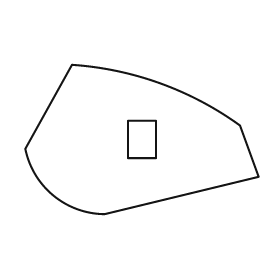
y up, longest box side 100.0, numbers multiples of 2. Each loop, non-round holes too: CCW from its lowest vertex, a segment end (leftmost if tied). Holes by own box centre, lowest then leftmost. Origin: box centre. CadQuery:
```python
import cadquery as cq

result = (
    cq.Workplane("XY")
    .moveTo(-16.0, -32.0)
    .lineTo(50.0, -16.0)
    .lineTo(42.0, 6.0)
    .threePointArc((8.0, 24.0), (-30.0, 32.0))
    .lineTo(-50.0, -4.0)
    .threePointArc((-38.0, -24.0), (-16.0, -32.0))
    .close()
    .moveTo(-6.0, -8.0)
    .lineTo(6.0, -8.0)
    .lineTo(6.0, 8.0)
    .lineTo(-6.0, 8.0)
    .close()
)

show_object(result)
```